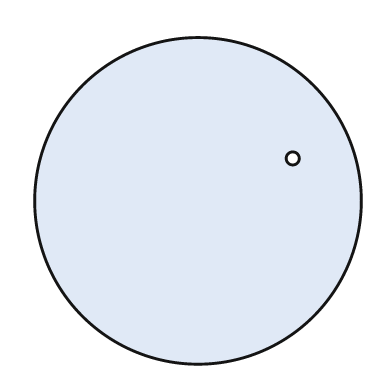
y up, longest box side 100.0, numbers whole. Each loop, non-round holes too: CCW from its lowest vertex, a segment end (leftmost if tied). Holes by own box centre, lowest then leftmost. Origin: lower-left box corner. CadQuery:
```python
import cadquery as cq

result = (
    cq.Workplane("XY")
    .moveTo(50.0, 50.0)
    .circle(50.0)
    .moveTo(79.0, 63.0)
    .circle(2.0)
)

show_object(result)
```